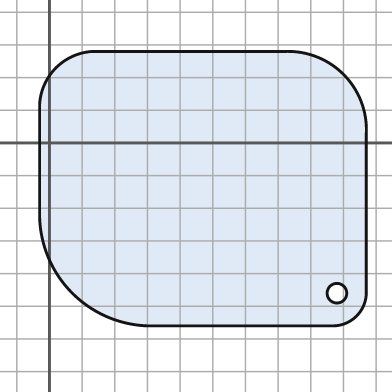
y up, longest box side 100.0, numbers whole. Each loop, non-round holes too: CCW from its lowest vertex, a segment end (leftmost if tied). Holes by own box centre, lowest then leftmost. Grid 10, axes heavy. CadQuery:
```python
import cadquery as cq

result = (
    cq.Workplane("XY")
    .moveTo(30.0, -56.0)
    .lineTo(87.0, -56.0)
    .threePointArc((94.0, -53.0), (97.0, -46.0))
    .lineTo(97.0, 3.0)
    .threePointArc((90.0, 21.0), (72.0, 28.0))
    .lineTo(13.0, 28.0)
    .threePointArc((2.0, 23.0), (-3.0, 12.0))
    .lineTo(-3.0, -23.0)
    .threePointArc((7.0, -46.0), (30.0, -56.0))
    .close()
    .moveTo(88.0, -46.0)
    .circle(3.0)
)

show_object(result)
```